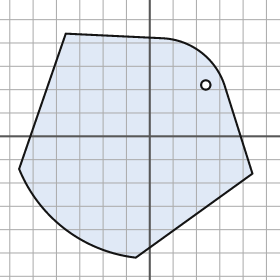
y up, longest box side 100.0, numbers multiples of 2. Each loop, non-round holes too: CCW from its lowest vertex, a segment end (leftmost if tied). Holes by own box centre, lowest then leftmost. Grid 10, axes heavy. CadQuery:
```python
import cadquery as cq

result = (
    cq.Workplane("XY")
    .moveTo(-6.0, -52.0)
    .lineTo(44.0, -16.0)
    .lineTo(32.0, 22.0)
    .threePointArc((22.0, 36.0), (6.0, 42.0))
    .lineTo(-36.0, 44.0)
    .lineTo(-56.0, -14.0)
    .threePointArc((-36.0, -40.0), (-6.0, -52.0))
    .close()
    .moveTo(24.0, 22.0)
    .circle(2.0)
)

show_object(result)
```